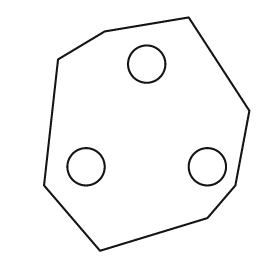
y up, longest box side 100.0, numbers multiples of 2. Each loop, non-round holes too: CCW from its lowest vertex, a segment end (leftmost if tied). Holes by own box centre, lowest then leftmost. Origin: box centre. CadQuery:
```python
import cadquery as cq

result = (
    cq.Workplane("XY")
    .moveTo(-20.0, -50.0)
    .lineTo(26.0, -36.0)
    .lineTo(38.0, -22.0)
    .lineTo(44.0, 10.0)
    .lineTo(18.0, 50.0)
    .lineTo(-18.0, 44.0)
    .lineTo(-38.0, 32.0)
    .lineTo(-44.0, -22.0)
    .close()
    .moveTo(-26.0, -14.0)
    .circle(8.0)
    .moveTo(26.0, -14.0)
    .circle(8.0)
    .moveTo(0.0, 30.0)
    .circle(8.0)
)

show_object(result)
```